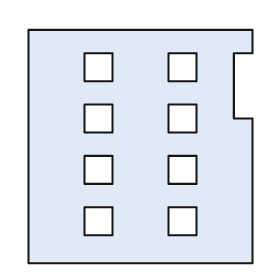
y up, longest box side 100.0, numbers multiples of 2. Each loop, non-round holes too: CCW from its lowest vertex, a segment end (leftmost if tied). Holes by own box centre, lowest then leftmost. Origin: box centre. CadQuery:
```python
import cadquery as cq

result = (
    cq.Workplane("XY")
    .moveTo(-48.0, -50.0)
    .lineTo(48.0, -50.0)
    .lineTo(48.0, 12.0)
    .lineTo(40.0, 12.0)
    .lineTo(40.0, 40.0)
    .lineTo(48.0, 40.0)
    .lineTo(48.0, 50.0)
    .lineTo(-48.0, 50.0)
    .close()
    .moveTo(-24.0, -38.0)
    .lineTo(-12.0, -38.0)
    .lineTo(-12.0, -26.0)
    .lineTo(-24.0, -26.0)
    .close()
    .moveTo(12.0, -38.0)
    .lineTo(24.0, -38.0)
    .lineTo(24.0, -26.0)
    .lineTo(12.0, -26.0)
    .close()
    .moveTo(-24.0, -16.0)
    .lineTo(-12.0, -16.0)
    .lineTo(-12.0, -4.0)
    .lineTo(-24.0, -4.0)
    .close()
    .moveTo(12.0, -16.0)
    .lineTo(24.0, -16.0)
    .lineTo(24.0, -4.0)
    .lineTo(12.0, -4.0)
    .close()
    .moveTo(-24.0, 6.0)
    .lineTo(-12.0, 6.0)
    .lineTo(-12.0, 18.0)
    .lineTo(-24.0, 18.0)
    .close()
    .moveTo(12.0, 6.0)
    .lineTo(24.0, 6.0)
    .lineTo(24.0, 18.0)
    .lineTo(12.0, 18.0)
    .close()
    .moveTo(-24.0, 28.0)
    .lineTo(-12.0, 28.0)
    .lineTo(-12.0, 40.0)
    .lineTo(-24.0, 40.0)
    .close()
    .moveTo(12.0, 28.0)
    .lineTo(24.0, 28.0)
    .lineTo(24.0, 40.0)
    .lineTo(12.0, 40.0)
    .close()
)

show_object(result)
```